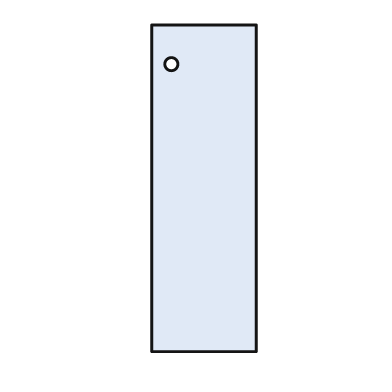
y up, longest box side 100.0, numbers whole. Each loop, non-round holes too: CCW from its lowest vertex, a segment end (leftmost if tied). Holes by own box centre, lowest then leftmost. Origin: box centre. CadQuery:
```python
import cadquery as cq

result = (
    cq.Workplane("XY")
    .moveTo(-16.0, -50.0)
    .lineTo(16.0, -50.0)
    .lineTo(16.0, 50.0)
    .lineTo(-16.0, 50.0)
    .close()
    .moveTo(-10.0, 38.0)
    .circle(2.0)
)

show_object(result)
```